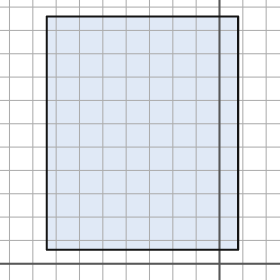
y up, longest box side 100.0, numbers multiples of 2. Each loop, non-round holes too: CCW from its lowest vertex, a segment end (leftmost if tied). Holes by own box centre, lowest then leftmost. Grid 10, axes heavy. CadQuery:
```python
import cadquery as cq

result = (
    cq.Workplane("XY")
    .moveTo(-74.0, 6.0)
    .lineTo(8.0, 6.0)
    .lineTo(8.0, 106.0)
    .lineTo(-74.0, 106.0)
    .close()
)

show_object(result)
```